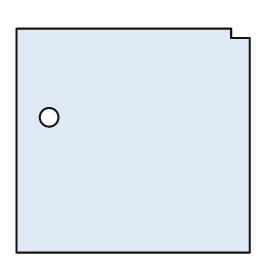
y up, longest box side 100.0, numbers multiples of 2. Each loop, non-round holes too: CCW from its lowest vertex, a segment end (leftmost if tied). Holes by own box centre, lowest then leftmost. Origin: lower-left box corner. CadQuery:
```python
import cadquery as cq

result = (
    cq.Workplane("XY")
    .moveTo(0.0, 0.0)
    .lineTo(100.0, 0.0)
    .lineTo(100.0, 92.0)
    .lineTo(92.0, 92.0)
    .lineTo(92.0, 96.0)
    .lineTo(0.0, 96.0)
    .close()
    .moveTo(14.0, 58.0)
    .circle(4.0)
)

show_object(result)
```